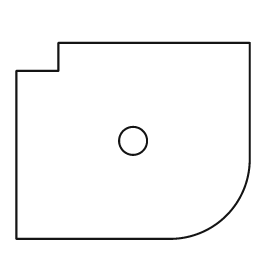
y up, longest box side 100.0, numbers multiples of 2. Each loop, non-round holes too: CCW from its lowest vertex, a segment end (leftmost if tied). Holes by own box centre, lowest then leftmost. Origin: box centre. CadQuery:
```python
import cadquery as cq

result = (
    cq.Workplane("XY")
    .moveTo(-50.0, -42.0)
    .lineTo(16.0, -42.0)
    .threePointArc((40.0, -32.0), (50.0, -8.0))
    .lineTo(50.0, 42.0)
    .lineTo(-32.0, 42.0)
    .lineTo(-32.0, 30.0)
    .lineTo(-50.0, 30.0)
    .close()
    .moveTo(0.0, 0.0)
    .circle(6.0)
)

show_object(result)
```